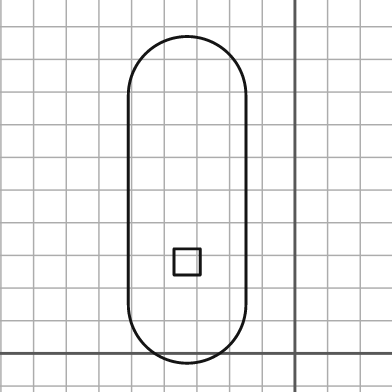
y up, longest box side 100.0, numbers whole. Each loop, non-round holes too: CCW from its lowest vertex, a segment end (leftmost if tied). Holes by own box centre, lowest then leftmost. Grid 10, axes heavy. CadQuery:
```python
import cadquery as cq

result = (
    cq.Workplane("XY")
    .moveTo(-51.0, 15.0)
    .threePointArc((-33.0, -3.0), (-15.0, 15.0))
    .lineTo(-15.0, 79.0)
    .threePointArc((-33.0, 97.0), (-51.0, 79.0))
    .close()
    .moveTo(-37.0, 24.0)
    .lineTo(-29.0, 24.0)
    .lineTo(-29.0, 32.0)
    .lineTo(-37.0, 32.0)
    .close()
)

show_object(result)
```